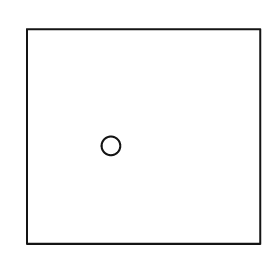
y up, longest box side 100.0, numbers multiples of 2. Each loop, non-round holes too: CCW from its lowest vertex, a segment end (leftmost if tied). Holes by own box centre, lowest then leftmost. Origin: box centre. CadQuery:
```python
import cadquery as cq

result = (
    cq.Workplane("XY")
    .moveTo(-50.0, -46.0)
    .lineTo(50.0, -46.0)
    .lineTo(50.0, 46.0)
    .lineTo(-50.0, 46.0)
    .close()
    .moveTo(-14.0, -4.0)
    .circle(4.0)
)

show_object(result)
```